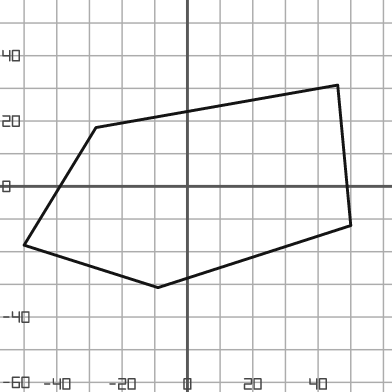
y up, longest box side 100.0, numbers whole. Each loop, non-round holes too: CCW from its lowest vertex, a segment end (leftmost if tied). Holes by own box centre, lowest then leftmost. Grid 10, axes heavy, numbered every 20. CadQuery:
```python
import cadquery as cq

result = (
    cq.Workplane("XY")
    .moveTo(-9.0, -31.0)
    .lineTo(50.0, -12.0)
    .lineTo(46.0, 31.0)
    .lineTo(-28.0, 18.0)
    .lineTo(-50.0, -18.0)
    .close()
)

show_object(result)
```